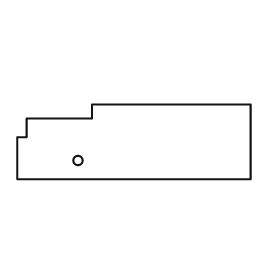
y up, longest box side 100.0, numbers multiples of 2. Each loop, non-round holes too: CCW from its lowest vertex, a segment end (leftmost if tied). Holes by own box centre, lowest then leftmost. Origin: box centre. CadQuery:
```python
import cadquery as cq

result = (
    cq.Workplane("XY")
    .moveTo(-50.0, -16.0)
    .lineTo(50.0, -16.0)
    .lineTo(50.0, 16.0)
    .lineTo(-18.0, 16.0)
    .lineTo(-18.0, 10.0)
    .lineTo(-46.0, 10.0)
    .lineTo(-46.0, 2.0)
    .lineTo(-50.0, 2.0)
    .close()
    .moveTo(-24.0, -8.0)
    .circle(2.0)
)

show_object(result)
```